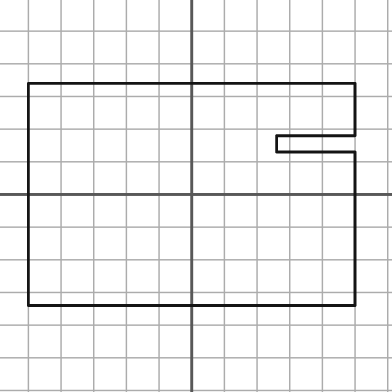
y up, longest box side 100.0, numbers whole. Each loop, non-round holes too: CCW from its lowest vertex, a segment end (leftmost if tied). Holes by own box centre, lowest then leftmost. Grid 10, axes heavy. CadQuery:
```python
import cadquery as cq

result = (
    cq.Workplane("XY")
    .moveTo(-50.0, -34.0)
    .lineTo(50.0, -34.0)
    .lineTo(50.0, 13.0)
    .lineTo(26.0, 13.0)
    .lineTo(26.0, 18.0)
    .lineTo(50.0, 18.0)
    .lineTo(50.0, 34.0)
    .lineTo(-50.0, 34.0)
    .close()
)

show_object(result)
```